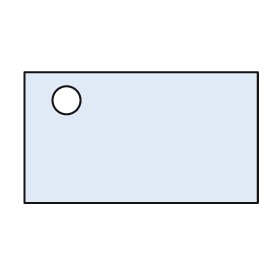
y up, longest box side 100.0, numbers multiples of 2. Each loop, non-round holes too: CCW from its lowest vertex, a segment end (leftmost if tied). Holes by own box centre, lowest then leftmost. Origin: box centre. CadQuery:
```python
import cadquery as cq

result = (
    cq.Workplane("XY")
    .moveTo(-50.0, -28.0)
    .lineTo(50.0, -28.0)
    .lineTo(50.0, 28.0)
    .lineTo(-50.0, 28.0)
    .close()
    .moveTo(-32.0, 16.0)
    .circle(6.0)
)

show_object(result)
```